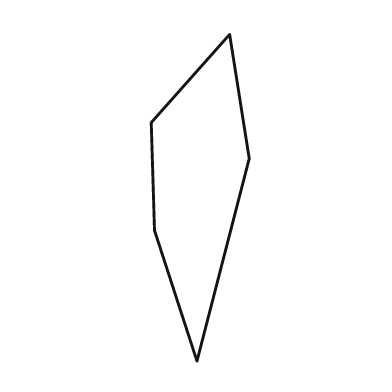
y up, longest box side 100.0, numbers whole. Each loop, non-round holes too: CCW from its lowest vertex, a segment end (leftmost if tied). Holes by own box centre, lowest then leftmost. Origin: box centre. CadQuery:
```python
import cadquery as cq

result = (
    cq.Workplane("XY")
    .moveTo(-1.0, -50.0)
    .lineTo(15.0, 12.0)
    .lineTo(9.0, 50.0)
    .lineTo(-15.0, 23.0)
    .lineTo(-14.0, -10.0)
    .close()
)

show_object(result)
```